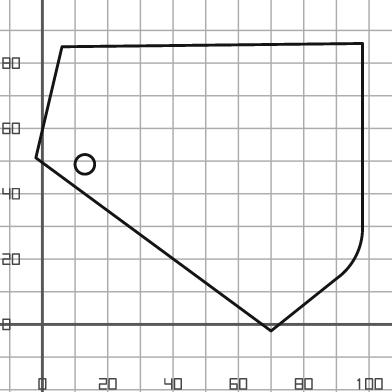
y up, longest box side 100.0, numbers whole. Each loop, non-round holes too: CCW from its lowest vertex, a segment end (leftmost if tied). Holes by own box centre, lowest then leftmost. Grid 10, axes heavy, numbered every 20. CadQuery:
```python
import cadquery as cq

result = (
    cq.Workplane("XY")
    .moveTo(70.0, -2.0)
    .lineTo(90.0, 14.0)
    .threePointArc((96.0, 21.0), (98.0, 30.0))
    .lineTo(98.0, 86.0)
    .lineTo(6.0, 85.0)
    .lineTo(-2.0, 51.0)
    .close()
    .moveTo(13.0, 49.0)
    .circle(3.0)
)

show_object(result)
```